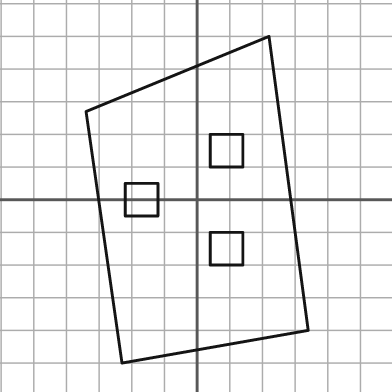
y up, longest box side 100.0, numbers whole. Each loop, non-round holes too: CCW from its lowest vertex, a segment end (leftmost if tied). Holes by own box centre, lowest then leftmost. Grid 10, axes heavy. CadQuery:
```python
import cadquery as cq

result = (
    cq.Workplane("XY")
    .moveTo(-23.0, -50.0)
    .lineTo(34.0, -40.0)
    .lineTo(22.0, 50.0)
    .lineTo(-34.0, 27.0)
    .close()
    .moveTo(4.0, -20.0)
    .lineTo(14.0, -20.0)
    .lineTo(14.0, -10.0)
    .lineTo(4.0, -10.0)
    .close()
    .moveTo(-22.0, -5.0)
    .lineTo(-12.0, -5.0)
    .lineTo(-12.0, 5.0)
    .lineTo(-22.0, 5.0)
    .close()
    .moveTo(4.0, 10.0)
    .lineTo(14.0, 10.0)
    .lineTo(14.0, 20.0)
    .lineTo(4.0, 20.0)
    .close()
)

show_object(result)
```